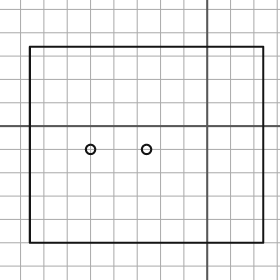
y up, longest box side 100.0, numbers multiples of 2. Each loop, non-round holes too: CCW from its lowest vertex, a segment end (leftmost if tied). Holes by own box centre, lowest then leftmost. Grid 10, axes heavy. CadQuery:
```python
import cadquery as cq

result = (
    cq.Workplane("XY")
    .moveTo(-76.0, -50.0)
    .lineTo(24.0, -50.0)
    .lineTo(24.0, 34.0)
    .lineTo(-76.0, 34.0)
    .close()
    .moveTo(-50.0, -10.0)
    .circle(2.0)
    .moveTo(-26.0, -10.0)
    .circle(2.0)
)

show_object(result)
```